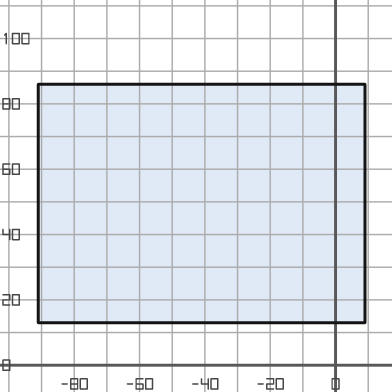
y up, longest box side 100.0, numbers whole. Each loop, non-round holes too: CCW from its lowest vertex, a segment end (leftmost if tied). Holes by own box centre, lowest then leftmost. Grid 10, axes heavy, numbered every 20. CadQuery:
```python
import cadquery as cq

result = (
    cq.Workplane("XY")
    .moveTo(-91.0, 13.0)
    .lineTo(9.0, 13.0)
    .lineTo(9.0, 86.0)
    .lineTo(-91.0, 86.0)
    .close()
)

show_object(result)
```